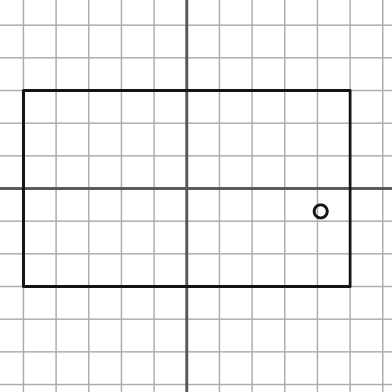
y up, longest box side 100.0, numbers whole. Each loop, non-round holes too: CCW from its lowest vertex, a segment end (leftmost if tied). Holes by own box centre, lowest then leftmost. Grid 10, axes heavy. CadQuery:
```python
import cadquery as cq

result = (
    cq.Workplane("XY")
    .moveTo(-50.0, -30.0)
    .lineTo(50.0, -30.0)
    .lineTo(50.0, 30.0)
    .lineTo(-50.0, 30.0)
    .close()
    .moveTo(41.0, -7.0)
    .circle(2.0)
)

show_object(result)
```